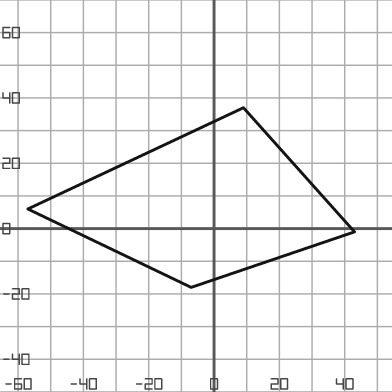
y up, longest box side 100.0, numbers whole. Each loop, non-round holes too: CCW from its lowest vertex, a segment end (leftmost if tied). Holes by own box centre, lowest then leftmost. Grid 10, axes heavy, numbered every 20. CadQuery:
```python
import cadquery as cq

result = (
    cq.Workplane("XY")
    .moveTo(-7.0, -18.0)
    .lineTo(43.0, -1.0)
    .lineTo(9.0, 37.0)
    .lineTo(-57.0, 6.0)
    .close()
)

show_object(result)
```